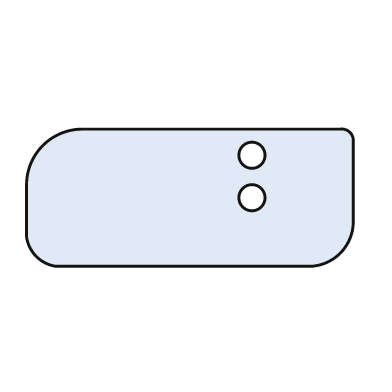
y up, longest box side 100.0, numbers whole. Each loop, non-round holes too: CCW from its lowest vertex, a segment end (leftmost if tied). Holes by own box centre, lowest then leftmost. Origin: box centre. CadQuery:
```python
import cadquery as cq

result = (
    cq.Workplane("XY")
    .moveTo(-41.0, -21.0)
    .lineTo(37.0, -21.0)
    .threePointArc((46.0, -17.0), (50.0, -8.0))
    .lineTo(50.0, 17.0)
    .threePointArc((49.0, 20.0), (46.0, 21.0))
    .lineTo(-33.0, 21.0)
    .threePointArc((-45.0, 16.0), (-50.0, 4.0))
    .lineTo(-50.0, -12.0)
    .threePointArc((-47.0, -18.0), (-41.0, -21.0))
    .close()
    .moveTo(19.0, 0.0)
    .circle(4.0)
    .moveTo(19.0, 13.0)
    .circle(4.0)
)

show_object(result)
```